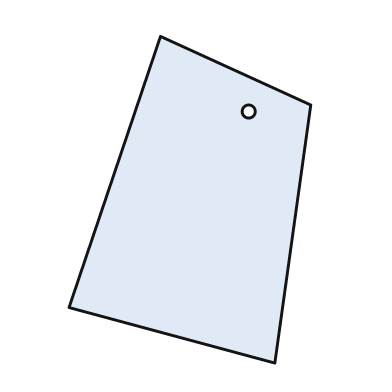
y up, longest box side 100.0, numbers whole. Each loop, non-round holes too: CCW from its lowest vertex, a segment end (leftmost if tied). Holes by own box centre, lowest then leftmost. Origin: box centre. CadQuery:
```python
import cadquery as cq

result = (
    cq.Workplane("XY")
    .moveTo(26.0, -50.0)
    .lineTo(37.0, 29.0)
    .lineTo(-9.0, 50.0)
    .lineTo(-37.0, -33.0)
    .close()
    .moveTo(18.0, 27.0)
    .circle(2.0)
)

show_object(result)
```